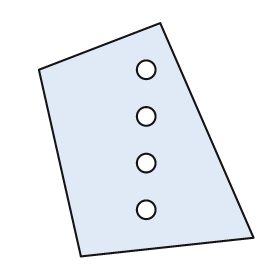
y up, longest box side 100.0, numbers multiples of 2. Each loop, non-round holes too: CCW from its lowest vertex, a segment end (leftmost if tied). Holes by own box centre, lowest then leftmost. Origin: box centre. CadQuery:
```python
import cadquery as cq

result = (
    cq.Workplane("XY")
    .moveTo(-28.0, -50.0)
    .lineTo(46.0, -42.0)
    .lineTo(6.0, 50.0)
    .lineTo(-46.0, 30.0)
    .close()
    .moveTo(0.0, -30.0)
    .circle(4.0)
    .moveTo(0.0, -10.0)
    .circle(4.0)
    .moveTo(0.0, 10.0)
    .circle(4.0)
    .moveTo(0.0, 30.0)
    .circle(4.0)
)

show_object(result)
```